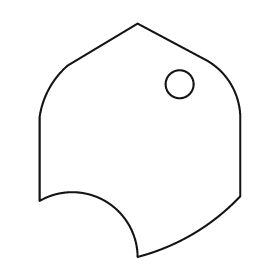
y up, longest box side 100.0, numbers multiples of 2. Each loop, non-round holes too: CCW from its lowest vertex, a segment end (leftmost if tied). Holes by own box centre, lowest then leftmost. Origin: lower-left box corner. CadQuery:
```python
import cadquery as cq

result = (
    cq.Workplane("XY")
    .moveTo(42.0, 0.0)
    .threePointArc((66.0, 10.0), (86.0, 26.0))
    .lineTo(86.0, 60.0)
    .threePointArc((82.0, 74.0), (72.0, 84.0))
    .lineTo(42.0, 100.0)
    .lineTo(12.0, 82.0)
    .threePointArc((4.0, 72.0), (0.0, 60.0))
    .lineTo(0.0, 24.0)
    .threePointArc((28.0, 24.0), (42.0, 0.0))
    .close()
    .moveTo(60.0, 74.0)
    .circle(6.0)
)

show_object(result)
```